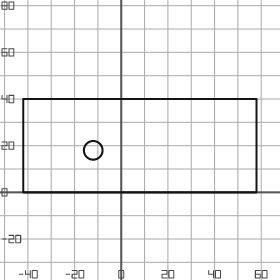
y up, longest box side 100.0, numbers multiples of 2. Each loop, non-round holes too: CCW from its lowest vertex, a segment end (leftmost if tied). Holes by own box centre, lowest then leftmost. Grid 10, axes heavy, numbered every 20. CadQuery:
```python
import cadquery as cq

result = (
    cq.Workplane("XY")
    .moveTo(-42.0, 0.0)
    .lineTo(58.0, 0.0)
    .lineTo(58.0, 40.0)
    .lineTo(-42.0, 40.0)
    .close()
    .moveTo(-12.0, 18.0)
    .circle(4.0)
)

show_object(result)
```